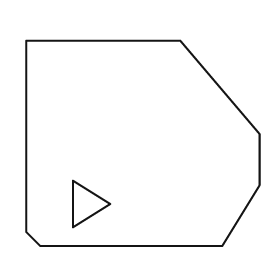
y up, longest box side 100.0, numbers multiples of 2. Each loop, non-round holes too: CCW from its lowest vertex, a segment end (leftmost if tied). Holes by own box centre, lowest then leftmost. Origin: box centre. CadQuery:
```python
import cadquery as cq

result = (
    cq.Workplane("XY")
    .moveTo(-44.0, -44.0)
    .lineTo(34.0, -44.0)
    .lineTo(50.0, -18.0)
    .lineTo(50.0, 4.0)
    .lineTo(16.0, 44.0)
    .lineTo(-50.0, 44.0)
    .lineTo(-50.0, -38.0)
    .close()
    .moveTo(-30.0, -36.0)
    .lineTo(-14.0, -26.0)
    .lineTo(-30.0, -16.0)
    .close()
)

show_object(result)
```